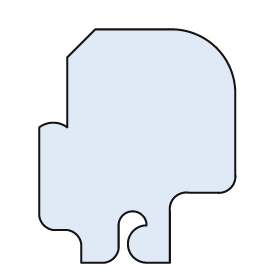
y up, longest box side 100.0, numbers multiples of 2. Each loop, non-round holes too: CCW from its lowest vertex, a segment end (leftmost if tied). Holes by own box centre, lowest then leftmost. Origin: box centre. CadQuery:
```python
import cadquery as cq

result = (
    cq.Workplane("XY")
    .moveTo(-24.0, -50.0)
    .lineTo(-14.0, -50.0)
    .threePointArc((-10.0, -48.0), (-8.0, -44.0))
    .lineTo(-8.0, -34.0)
    .threePointArc((-2.0, -28.0), (4.0, -34.0))
    .threePointArc((-4.0, -42.0), (4.0, -50.0))
    .lineTo(14.0, -50.0)
    .lineTo(14.0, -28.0)
    .threePointArc((16.0, -22.0), (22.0, -20.0))
    .lineTo(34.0, -20.0)
    .threePointArc((40.0, -18.0), (42.0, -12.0))
    .lineTo(42.0, 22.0)
    .threePointArc((34.0, 42.0), (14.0, 50.0))
    .lineTo(-18.0, 50.0)
    .lineTo(-30.0, 38.0)
    .lineTo(-30.0, 8.0)
    .threePointArc((-36.0, 10.0), (-42.0, 8.0))
    .lineTo(-42.0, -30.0)
    .threePointArc((-40.0, -34.0), (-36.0, -36.0))
    .lineTo(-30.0, -36.0)
    .threePointArc((-26.0, -38.0), (-24.0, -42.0))
    .close()
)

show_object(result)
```